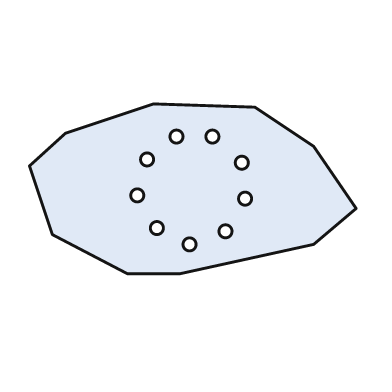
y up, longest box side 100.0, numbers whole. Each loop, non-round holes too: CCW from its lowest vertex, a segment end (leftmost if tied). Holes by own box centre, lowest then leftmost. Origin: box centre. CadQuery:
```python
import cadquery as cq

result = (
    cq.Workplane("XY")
    .moveTo(-20.0, -26.0)
    .lineTo(-4.0, -26.0)
    .lineTo(37.0, -17.0)
    .lineTo(50.0, -6.0)
    .lineTo(37.0, 13.0)
    .lineTo(19.0, 25.0)
    .lineTo(-12.0, 26.0)
    .lineTo(-39.0, 17.0)
    .lineTo(-50.0, 7.0)
    .lineTo(-43.0, -14.0)
    .close()
    .moveTo(-1.0, -17.0)
    .circle(2.0)
    .moveTo(10.0, -13.0)
    .circle(2.0)
    .moveTo(-11.0, -12.0)
    .circle(2.0)
    .moveTo(16.0, -3.0)
    .circle(2.0)
    .moveTo(-17.0, -2.0)
    .circle(2.0)
    .moveTo(15.0, 8.0)
    .circle(2.0)
    .moveTo(-14.0, 9.0)
    .circle(2.0)
    .moveTo(-5.0, 16.0)
    .circle(2.0)
    .moveTo(6.0, 16.0)
    .circle(2.0)
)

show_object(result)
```